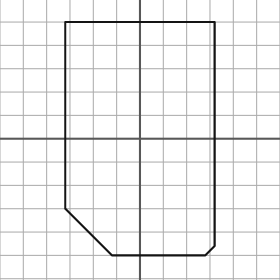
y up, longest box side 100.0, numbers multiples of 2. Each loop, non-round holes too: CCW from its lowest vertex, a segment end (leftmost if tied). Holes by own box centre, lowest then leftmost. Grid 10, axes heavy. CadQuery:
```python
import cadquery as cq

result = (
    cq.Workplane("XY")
    .moveTo(-12.0, -50.0)
    .lineTo(28.0, -50.0)
    .lineTo(32.0, -46.0)
    .lineTo(32.0, 50.0)
    .lineTo(-32.0, 50.0)
    .lineTo(-32.0, -30.0)
    .close()
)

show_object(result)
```